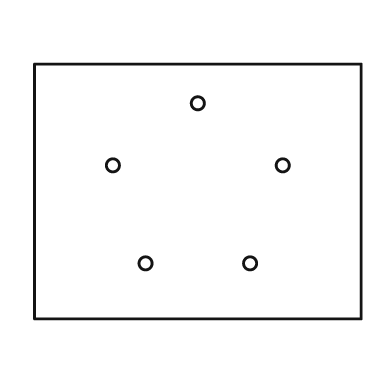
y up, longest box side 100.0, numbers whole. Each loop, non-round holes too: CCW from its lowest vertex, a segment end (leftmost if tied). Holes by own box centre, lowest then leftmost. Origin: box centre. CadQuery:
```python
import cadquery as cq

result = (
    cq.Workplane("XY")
    .moveTo(-50.0, -39.0)
    .lineTo(50.0, -39.0)
    .lineTo(50.0, 39.0)
    .lineTo(-50.0, 39.0)
    .close()
    .moveTo(-16.0, -22.0)
    .circle(2.0)
    .moveTo(16.0, -22.0)
    .circle(2.0)
    .moveTo(-26.0, 8.0)
    .circle(2.0)
    .moveTo(26.0, 8.0)
    .circle(2.0)
    .moveTo(0.0, 27.0)
    .circle(2.0)
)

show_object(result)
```